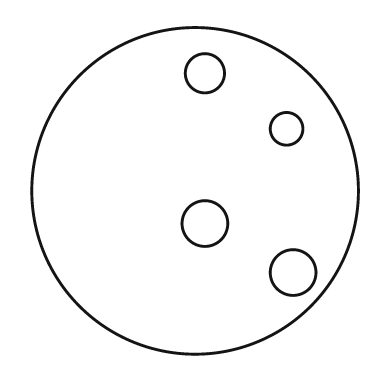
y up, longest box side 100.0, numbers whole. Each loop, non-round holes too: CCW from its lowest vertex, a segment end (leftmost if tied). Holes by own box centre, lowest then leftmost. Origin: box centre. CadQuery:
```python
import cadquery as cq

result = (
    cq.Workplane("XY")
    .moveTo(0.0, 0.0)
    .circle(50.0)
    .moveTo(30.0, -25.0)
    .circle(7.0)
    .moveTo(3.0, -10.0)
    .circle(7.0)
    .moveTo(28.0, 19.0)
    .circle(5.0)
    .moveTo(3.0, 36.0)
    .circle(6.0)
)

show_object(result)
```